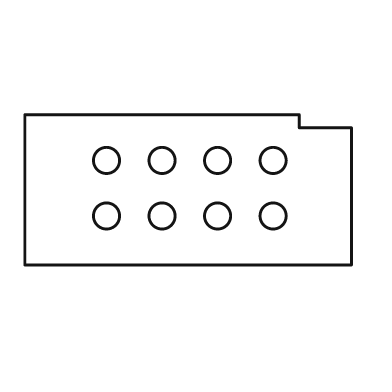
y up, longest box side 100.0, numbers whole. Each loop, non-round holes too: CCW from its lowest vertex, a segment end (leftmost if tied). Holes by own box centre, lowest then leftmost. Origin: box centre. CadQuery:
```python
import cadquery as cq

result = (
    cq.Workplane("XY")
    .moveTo(-50.0, -23.0)
    .lineTo(50.0, -23.0)
    .lineTo(50.0, 19.0)
    .lineTo(34.0, 19.0)
    .lineTo(34.0, 23.0)
    .lineTo(-50.0, 23.0)
    .close()
    .moveTo(-25.0, -8.0)
    .circle(4.0)
    .moveTo(-8.0, -8.0)
    .circle(4.0)
    .moveTo(9.0, -8.0)
    .circle(4.0)
    .moveTo(26.0, -8.0)
    .circle(4.0)
    .moveTo(-25.0, 9.0)
    .circle(4.0)
    .moveTo(-8.0, 9.0)
    .circle(4.0)
    .moveTo(9.0, 9.0)
    .circle(4.0)
    .moveTo(26.0, 9.0)
    .circle(4.0)
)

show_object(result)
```